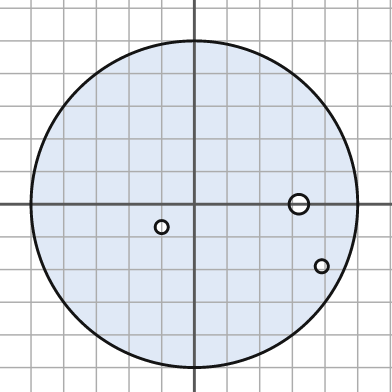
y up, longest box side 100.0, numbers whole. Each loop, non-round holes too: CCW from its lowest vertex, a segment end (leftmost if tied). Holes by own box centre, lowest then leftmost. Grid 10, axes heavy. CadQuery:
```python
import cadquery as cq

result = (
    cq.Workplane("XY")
    .moveTo(0.0, 0.0)
    .circle(50.0)
    .moveTo(39.0, -19.0)
    .circle(2.0)
    .moveTo(-10.0, -7.0)
    .circle(2.0)
    .moveTo(32.0, 0.0)
    .circle(3.0)
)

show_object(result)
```